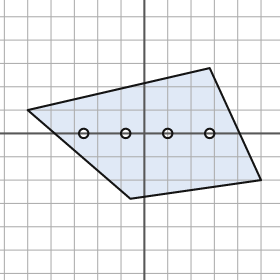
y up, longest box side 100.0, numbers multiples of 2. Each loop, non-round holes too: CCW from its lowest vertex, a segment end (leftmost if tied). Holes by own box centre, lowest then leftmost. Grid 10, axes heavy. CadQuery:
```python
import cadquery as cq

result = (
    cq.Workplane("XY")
    .moveTo(-6.0, -28.0)
    .lineTo(50.0, -20.0)
    .lineTo(28.0, 28.0)
    .lineTo(-50.0, 10.0)
    .close()
    .moveTo(-26.0, 0.0)
    .circle(2.0)
    .moveTo(-8.0, 0.0)
    .circle(2.0)
    .moveTo(10.0, 0.0)
    .circle(2.0)
    .moveTo(28.0, 0.0)
    .circle(2.0)
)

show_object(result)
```